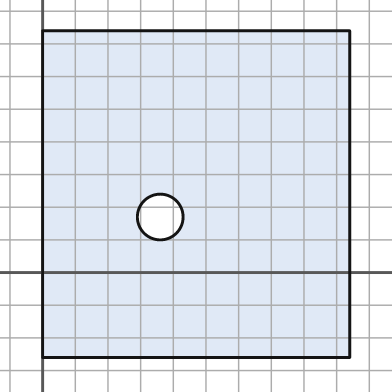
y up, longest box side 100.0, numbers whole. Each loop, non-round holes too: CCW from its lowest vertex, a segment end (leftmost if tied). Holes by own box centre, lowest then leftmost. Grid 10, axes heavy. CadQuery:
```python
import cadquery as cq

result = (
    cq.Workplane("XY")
    .moveTo(0.0, -26.0)
    .lineTo(94.0, -26.0)
    .lineTo(94.0, 74.0)
    .lineTo(0.0, 74.0)
    .close()
    .moveTo(36.0, 17.0)
    .circle(7.0)
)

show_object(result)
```